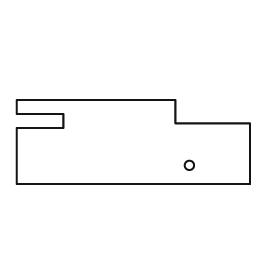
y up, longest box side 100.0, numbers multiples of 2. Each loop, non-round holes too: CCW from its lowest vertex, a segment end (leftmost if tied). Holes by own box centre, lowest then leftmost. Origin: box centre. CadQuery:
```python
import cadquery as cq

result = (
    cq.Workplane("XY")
    .moveTo(-50.0, -18.0)
    .lineTo(50.0, -18.0)
    .lineTo(50.0, 8.0)
    .lineTo(18.0, 8.0)
    .lineTo(18.0, 18.0)
    .lineTo(-50.0, 18.0)
    .lineTo(-50.0, 12.0)
    .lineTo(-30.0, 12.0)
    .lineTo(-30.0, 6.0)
    .lineTo(-50.0, 6.0)
    .close()
    .moveTo(24.0, -10.0)
    .circle(2.0)
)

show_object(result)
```